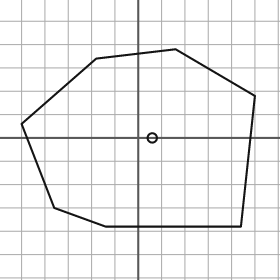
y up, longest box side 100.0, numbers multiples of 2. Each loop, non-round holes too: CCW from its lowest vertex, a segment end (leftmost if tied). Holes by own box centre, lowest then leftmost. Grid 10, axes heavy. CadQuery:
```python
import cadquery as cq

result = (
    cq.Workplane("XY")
    .moveTo(-14.0, -38.0)
    .lineTo(44.0, -38.0)
    .lineTo(50.0, 18.0)
    .lineTo(16.0, 38.0)
    .lineTo(-18.0, 34.0)
    .lineTo(-50.0, 6.0)
    .lineTo(-36.0, -30.0)
    .close()
    .moveTo(6.0, 0.0)
    .circle(2.0)
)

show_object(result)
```